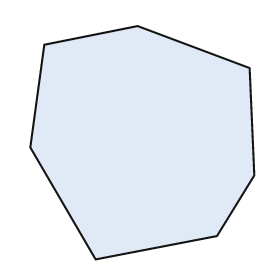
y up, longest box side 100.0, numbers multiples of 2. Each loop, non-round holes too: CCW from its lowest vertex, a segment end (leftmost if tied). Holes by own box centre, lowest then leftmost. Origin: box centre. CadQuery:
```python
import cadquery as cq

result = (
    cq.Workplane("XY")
    .moveTo(-20.0, -50.0)
    .lineTo(32.0, -40.0)
    .lineTo(48.0, -14.0)
    .lineTo(46.0, 32.0)
    .lineTo(-2.0, 50.0)
    .lineTo(-42.0, 42.0)
    .lineTo(-48.0, -2.0)
    .close()
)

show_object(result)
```